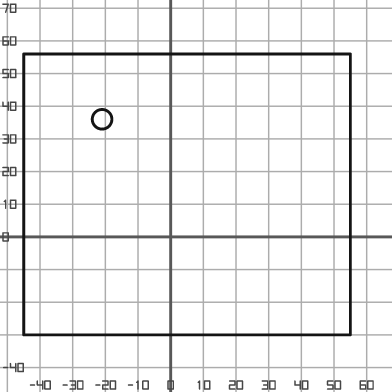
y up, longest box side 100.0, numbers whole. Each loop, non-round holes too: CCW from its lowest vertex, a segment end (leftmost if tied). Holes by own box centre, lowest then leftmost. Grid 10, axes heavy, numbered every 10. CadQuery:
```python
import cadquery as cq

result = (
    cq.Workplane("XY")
    .moveTo(-45.0, -30.0)
    .lineTo(55.0, -30.0)
    .lineTo(55.0, 56.0)
    .lineTo(-45.0, 56.0)
    .close()
    .moveTo(-21.0, 36.0)
    .circle(3.0)
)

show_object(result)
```